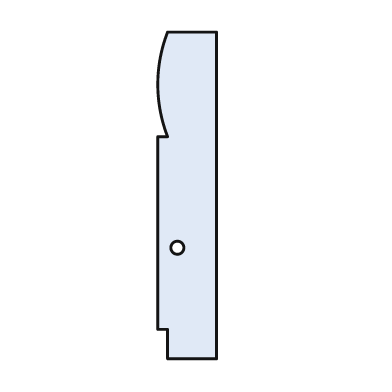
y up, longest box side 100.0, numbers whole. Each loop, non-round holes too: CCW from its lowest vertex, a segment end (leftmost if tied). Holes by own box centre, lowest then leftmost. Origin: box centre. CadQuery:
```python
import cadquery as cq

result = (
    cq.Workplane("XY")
    .moveTo(-6.0, -50.0)
    .lineTo(9.0, -50.0)
    .lineTo(9.0, 50.0)
    .lineTo(-6.0, 50.0)
    .threePointArc((-9.0, 34.0), (-6.0, 18.0))
    .lineTo(-9.0, 18.0)
    .lineTo(-9.0, -41.0)
    .lineTo(-6.0, -41.0)
    .close()
    .moveTo(-3.0, -16.0)
    .circle(2.0)
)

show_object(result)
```